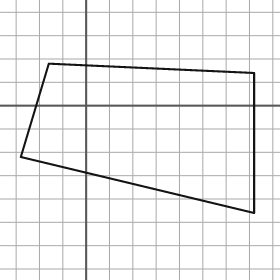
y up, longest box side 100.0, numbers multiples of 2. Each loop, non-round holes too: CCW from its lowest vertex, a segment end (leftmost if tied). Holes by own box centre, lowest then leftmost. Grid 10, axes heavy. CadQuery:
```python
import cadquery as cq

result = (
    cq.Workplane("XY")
    .moveTo(72.0, -46.0)
    .lineTo(72.0, 14.0)
    .lineTo(-16.0, 18.0)
    .lineTo(-28.0, -22.0)
    .close()
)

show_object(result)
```